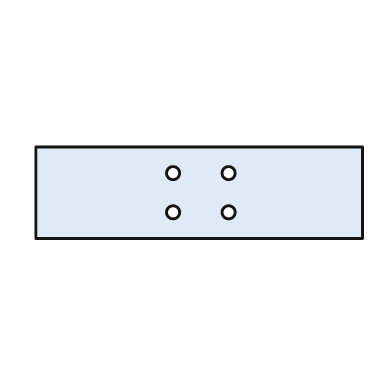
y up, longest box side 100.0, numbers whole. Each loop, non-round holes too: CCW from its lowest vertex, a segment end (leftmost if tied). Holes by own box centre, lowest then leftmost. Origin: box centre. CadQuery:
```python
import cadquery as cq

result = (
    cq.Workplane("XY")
    .moveTo(-50.0, -14.0)
    .lineTo(50.0, -14.0)
    .lineTo(50.0, 14.0)
    .lineTo(-50.0, 14.0)
    .close()
    .moveTo(-8.0, -6.0)
    .circle(2.0)
    .moveTo(9.0, -6.0)
    .circle(2.0)
    .moveTo(-8.0, 6.0)
    .circle(2.0)
    .moveTo(9.0, 6.0)
    .circle(2.0)
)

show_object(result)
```